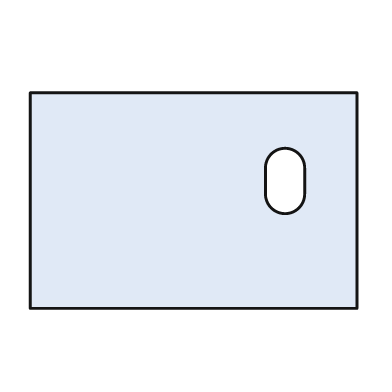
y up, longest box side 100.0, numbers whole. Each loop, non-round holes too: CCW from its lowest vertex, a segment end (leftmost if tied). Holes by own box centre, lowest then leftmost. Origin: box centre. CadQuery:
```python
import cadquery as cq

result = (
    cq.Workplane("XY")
    .moveTo(-50.0, -33.0)
    .lineTo(50.0, -33.0)
    .lineTo(50.0, 33.0)
    .lineTo(-50.0, 33.0)
    .close()
    .moveTo(22.0, 2.0)
    .threePointArc((28.0, -4.0), (34.0, 2.0))
    .lineTo(34.0, 10.0)
    .threePointArc((28.0, 16.0), (22.0, 10.0))
    .close()
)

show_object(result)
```